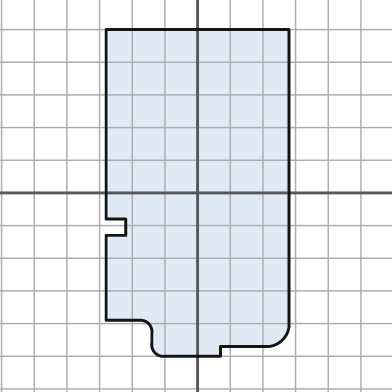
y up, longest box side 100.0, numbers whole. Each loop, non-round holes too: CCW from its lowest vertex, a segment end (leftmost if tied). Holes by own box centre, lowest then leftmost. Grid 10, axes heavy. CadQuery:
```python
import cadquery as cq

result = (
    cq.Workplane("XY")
    .moveTo(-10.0, -50.0)
    .lineTo(7.0, -50.0)
    .lineTo(7.0, -47.0)
    .lineTo(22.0, -47.0)
    .threePointArc((26.0, -45.0), (28.0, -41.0))
    .lineTo(28.0, 50.0)
    .lineTo(-28.0, 50.0)
    .lineTo(-28.0, -8.0)
    .lineTo(-22.0, -8.0)
    .lineTo(-22.0, -13.0)
    .lineTo(-28.0, -13.0)
    .lineTo(-28.0, -39.0)
    .lineTo(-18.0, -39.0)
    .threePointArc((-15.0, -40.0), (-14.0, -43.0))
    .lineTo(-14.0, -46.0)
    .threePointArc((-13.0, -49.0), (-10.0, -50.0))
    .close()
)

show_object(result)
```